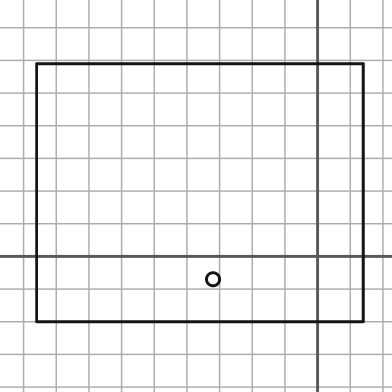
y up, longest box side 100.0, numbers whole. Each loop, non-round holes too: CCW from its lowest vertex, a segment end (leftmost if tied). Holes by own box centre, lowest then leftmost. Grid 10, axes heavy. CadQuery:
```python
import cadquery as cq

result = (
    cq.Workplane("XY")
    .moveTo(-86.0, -20.0)
    .lineTo(14.0, -20.0)
    .lineTo(14.0, 59.0)
    .lineTo(-86.0, 59.0)
    .close()
    .moveTo(-32.0, -7.0)
    .circle(2.0)
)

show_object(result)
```